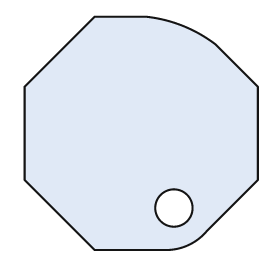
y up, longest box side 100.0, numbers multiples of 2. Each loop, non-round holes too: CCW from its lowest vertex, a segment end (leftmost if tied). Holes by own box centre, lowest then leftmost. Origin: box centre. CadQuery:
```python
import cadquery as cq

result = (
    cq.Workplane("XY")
    .moveTo(-20.0, -50.0)
    .lineTo(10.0, -50.0)
    .threePointArc((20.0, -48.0), (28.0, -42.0))
    .lineTo(50.0, -20.0)
    .lineTo(50.0, 20.0)
    .lineTo(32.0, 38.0)
    .threePointArc((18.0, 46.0), (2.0, 50.0))
    .lineTo(-20.0, 50.0)
    .lineTo(-50.0, 20.0)
    .lineTo(-50.0, -20.0)
    .close()
    .moveTo(14.0, -32.0)
    .circle(8.0)
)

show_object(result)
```